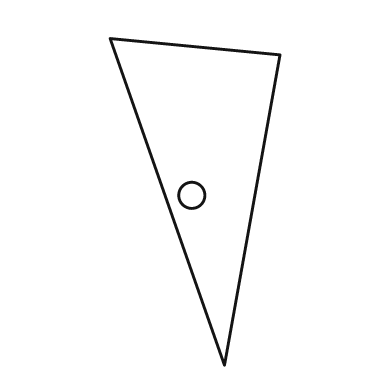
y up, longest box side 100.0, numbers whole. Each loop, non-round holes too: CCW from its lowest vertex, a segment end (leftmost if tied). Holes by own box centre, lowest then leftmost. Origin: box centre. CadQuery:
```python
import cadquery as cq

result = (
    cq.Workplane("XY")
    .moveTo(9.0, -50.0)
    .lineTo(26.0, 45.0)
    .lineTo(-26.0, 50.0)
    .close()
    .moveTo(-1.0, 2.0)
    .circle(4.0)
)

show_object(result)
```